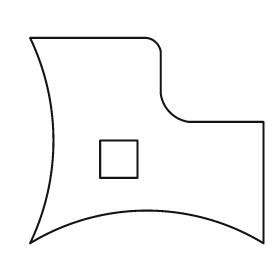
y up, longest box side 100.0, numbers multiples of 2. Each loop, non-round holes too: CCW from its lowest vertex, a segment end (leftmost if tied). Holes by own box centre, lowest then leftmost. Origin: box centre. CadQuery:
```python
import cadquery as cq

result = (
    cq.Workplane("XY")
    .moveTo(-50.0, -44.0)
    .threePointArc((0.0, -30.0), (50.0, -44.0))
    .lineTo(50.0, 8.0)
    .lineTo(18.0, 8.0)
    .threePointArc((10.0, 12.0), (6.0, 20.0))
    .lineTo(6.0, 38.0)
    .threePointArc((4.0, 42.0), (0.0, 44.0))
    .lineTo(-50.0, 44.0)
    .threePointArc((-40.0, 0.0), (-50.0, -44.0))
    .close()
    .moveTo(-20.0, -16.0)
    .lineTo(-4.0, -16.0)
    .lineTo(-4.0, 0.0)
    .lineTo(-20.0, 0.0)
    .close()
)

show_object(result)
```